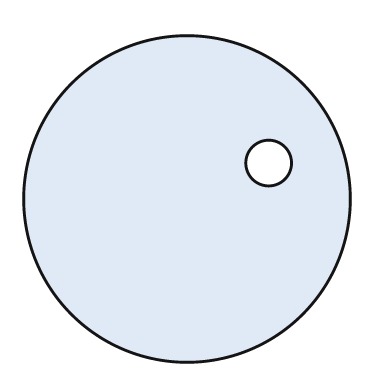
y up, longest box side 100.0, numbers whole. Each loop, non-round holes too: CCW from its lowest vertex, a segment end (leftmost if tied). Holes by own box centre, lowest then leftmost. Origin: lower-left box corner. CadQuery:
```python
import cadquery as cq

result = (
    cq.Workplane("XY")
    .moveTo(50.0, 50.0)
    .circle(50.0)
    .moveTo(75.0, 61.0)
    .circle(7.0)
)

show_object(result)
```